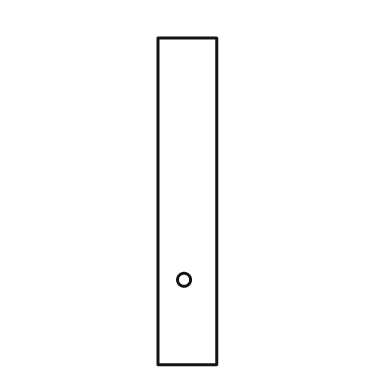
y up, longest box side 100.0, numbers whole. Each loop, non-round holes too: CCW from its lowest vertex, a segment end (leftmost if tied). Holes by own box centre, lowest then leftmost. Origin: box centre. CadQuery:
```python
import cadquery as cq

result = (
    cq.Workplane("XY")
    .moveTo(-9.0, -50.0)
    .lineTo(9.0, -50.0)
    .lineTo(9.0, 50.0)
    .lineTo(-9.0, 50.0)
    .close()
    .moveTo(-1.0, -24.0)
    .circle(2.0)
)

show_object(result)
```